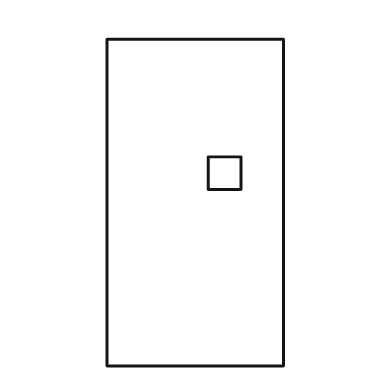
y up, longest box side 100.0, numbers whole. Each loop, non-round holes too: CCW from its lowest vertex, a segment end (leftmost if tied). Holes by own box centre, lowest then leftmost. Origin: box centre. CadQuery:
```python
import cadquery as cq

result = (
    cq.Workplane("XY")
    .moveTo(-27.0, -50.0)
    .lineTo(27.0, -50.0)
    .lineTo(27.0, 50.0)
    .lineTo(-27.0, 50.0)
    .close()
    .moveTo(4.0, 4.0)
    .lineTo(14.0, 4.0)
    .lineTo(14.0, 14.0)
    .lineTo(4.0, 14.0)
    .close()
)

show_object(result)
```